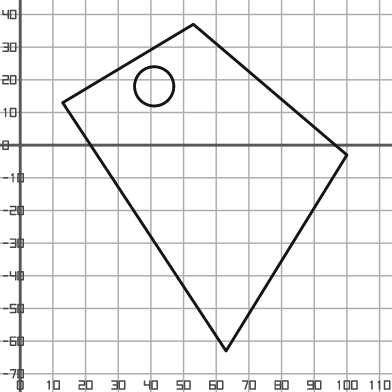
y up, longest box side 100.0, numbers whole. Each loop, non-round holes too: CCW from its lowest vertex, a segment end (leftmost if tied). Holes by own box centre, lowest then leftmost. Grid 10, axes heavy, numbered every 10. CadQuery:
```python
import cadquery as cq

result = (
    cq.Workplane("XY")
    .moveTo(63.0, -63.0)
    .lineTo(100.0, -3.0)
    .lineTo(53.0, 37.0)
    .lineTo(13.0, 13.0)
    .close()
    .moveTo(41.0, 18.0)
    .circle(6.0)
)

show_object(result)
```